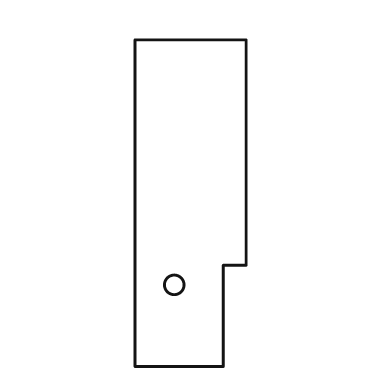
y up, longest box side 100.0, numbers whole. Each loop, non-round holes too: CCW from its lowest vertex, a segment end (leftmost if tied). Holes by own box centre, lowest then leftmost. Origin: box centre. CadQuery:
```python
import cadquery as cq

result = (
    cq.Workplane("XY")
    .moveTo(-17.0, -50.0)
    .lineTo(10.0, -50.0)
    .lineTo(10.0, -19.0)
    .lineTo(17.0, -19.0)
    .lineTo(17.0, 50.0)
    .lineTo(-17.0, 50.0)
    .close()
    .moveTo(-5.0, -25.0)
    .circle(3.0)
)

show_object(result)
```